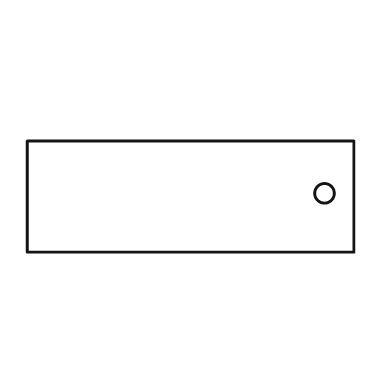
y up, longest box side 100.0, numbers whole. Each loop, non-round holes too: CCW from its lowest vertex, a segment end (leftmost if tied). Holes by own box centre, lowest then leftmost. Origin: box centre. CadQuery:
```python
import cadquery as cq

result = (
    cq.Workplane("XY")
    .moveTo(-50.0, -17.0)
    .lineTo(50.0, -17.0)
    .lineTo(50.0, 17.0)
    .lineTo(-50.0, 17.0)
    .close()
    .moveTo(41.0, 1.0)
    .circle(3.0)
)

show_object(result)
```